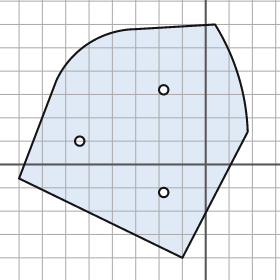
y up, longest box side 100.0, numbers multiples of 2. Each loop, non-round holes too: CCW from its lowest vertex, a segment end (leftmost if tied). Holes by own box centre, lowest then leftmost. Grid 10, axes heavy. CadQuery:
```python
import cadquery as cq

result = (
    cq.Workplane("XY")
    .moveTo(-10.0, -40.0)
    .lineTo(18.0, 14.0)
    .threePointArc((14.0, 38.0), (4.0, 60.0))
    .lineTo(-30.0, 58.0)
    .threePointArc((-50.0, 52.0), (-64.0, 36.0))
    .lineTo(-80.0, -6.0)
    .close()
    .moveTo(-18.0, -12.0)
    .circle(2.0)
    .moveTo(-54.0, 10.0)
    .circle(2.0)
    .moveTo(-18.0, 32.0)
    .circle(2.0)
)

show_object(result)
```